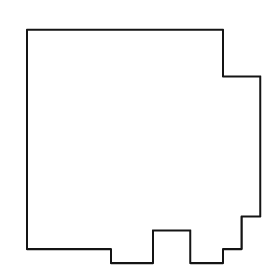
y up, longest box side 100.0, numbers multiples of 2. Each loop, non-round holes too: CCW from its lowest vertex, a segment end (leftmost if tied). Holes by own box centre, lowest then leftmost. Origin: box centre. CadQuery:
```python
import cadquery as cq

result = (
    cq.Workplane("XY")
    .moveTo(-14.0, -50.0)
    .lineTo(4.0, -50.0)
    .lineTo(4.0, -36.0)
    .lineTo(20.0, -36.0)
    .lineTo(20.0, -50.0)
    .lineTo(34.0, -50.0)
    .lineTo(34.0, -44.0)
    .lineTo(42.0, -44.0)
    .lineTo(42.0, -30.0)
    .lineTo(50.0, -30.0)
    .lineTo(50.0, 30.0)
    .lineTo(34.0, 30.0)
    .lineTo(34.0, 50.0)
    .lineTo(-50.0, 50.0)
    .lineTo(-50.0, -44.0)
    .lineTo(-14.0, -44.0)
    .close()
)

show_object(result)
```